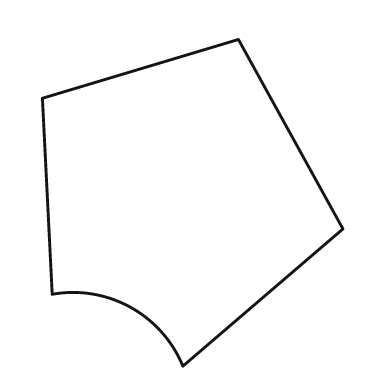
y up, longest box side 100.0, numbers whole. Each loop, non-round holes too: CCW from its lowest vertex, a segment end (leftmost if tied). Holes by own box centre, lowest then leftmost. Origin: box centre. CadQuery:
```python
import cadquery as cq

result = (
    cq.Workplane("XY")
    .moveTo(-3.0, -50.0)
    .lineTo(46.0, -8.0)
    .lineTo(14.0, 50.0)
    .lineTo(-46.0, 32.0)
    .lineTo(-43.0, -28.0)
    .threePointArc((-19.0, -32.0), (-3.0, -50.0))
    .close()
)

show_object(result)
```